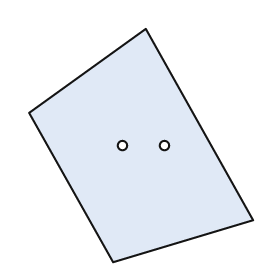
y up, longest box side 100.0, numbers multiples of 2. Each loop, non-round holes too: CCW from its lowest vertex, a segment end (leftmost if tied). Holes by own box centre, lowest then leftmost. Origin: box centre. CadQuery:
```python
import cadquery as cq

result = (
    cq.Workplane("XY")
    .moveTo(-12.0, -50.0)
    .lineTo(48.0, -32.0)
    .lineTo(2.0, 50.0)
    .lineTo(-48.0, 14.0)
    .close()
    .moveTo(-8.0, 0.0)
    .circle(2.0)
    .moveTo(10.0, 0.0)
    .circle(2.0)
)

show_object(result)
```